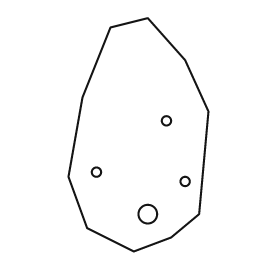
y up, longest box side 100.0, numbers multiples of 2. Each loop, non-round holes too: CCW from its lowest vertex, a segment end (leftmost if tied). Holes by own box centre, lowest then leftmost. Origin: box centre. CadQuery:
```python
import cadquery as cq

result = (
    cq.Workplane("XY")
    .moveTo(-2.0, -50.0)
    .lineTo(14.0, -44.0)
    .lineTo(26.0, -34.0)
    .lineTo(30.0, 10.0)
    .lineTo(20.0, 32.0)
    .lineTo(4.0, 50.0)
    .lineTo(-12.0, 46.0)
    .lineTo(-24.0, 16.0)
    .lineTo(-30.0, -18.0)
    .lineTo(-22.0, -40.0)
    .close()
    .moveTo(4.0, -34.0)
    .circle(4.0)
    .moveTo(20.0, -20.0)
    .circle(2.0)
    .moveTo(-18.0, -16.0)
    .circle(2.0)
    .moveTo(12.0, 6.0)
    .circle(2.0)
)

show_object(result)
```